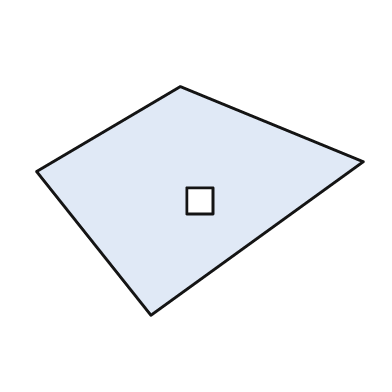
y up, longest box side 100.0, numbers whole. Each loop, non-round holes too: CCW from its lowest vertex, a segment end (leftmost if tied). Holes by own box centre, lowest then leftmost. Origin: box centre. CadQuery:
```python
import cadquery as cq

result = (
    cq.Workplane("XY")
    .moveTo(-15.0, -35.0)
    .lineTo(50.0, 12.0)
    .lineTo(-6.0, 35.0)
    .lineTo(-50.0, 9.0)
    .close()
    .moveTo(-4.0, -4.0)
    .lineTo(4.0, -4.0)
    .lineTo(4.0, 4.0)
    .lineTo(-4.0, 4.0)
    .close()
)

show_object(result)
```